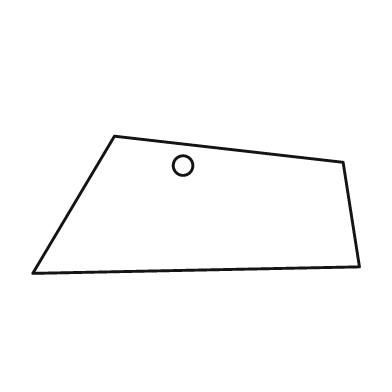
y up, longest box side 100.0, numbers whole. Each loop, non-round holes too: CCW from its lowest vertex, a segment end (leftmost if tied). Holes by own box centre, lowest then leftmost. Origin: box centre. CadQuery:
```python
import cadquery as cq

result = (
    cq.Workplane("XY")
    .moveTo(-50.0, -21.0)
    .lineTo(50.0, -19.0)
    .lineTo(45.0, 13.0)
    .lineTo(-25.0, 21.0)
    .close()
    .moveTo(-4.0, 12.0)
    .circle(3.0)
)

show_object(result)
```